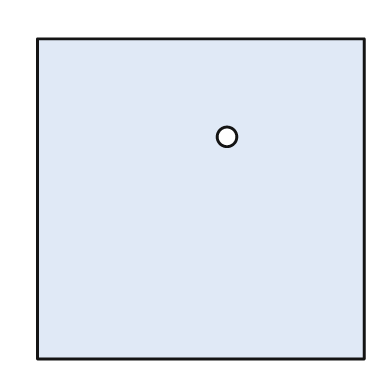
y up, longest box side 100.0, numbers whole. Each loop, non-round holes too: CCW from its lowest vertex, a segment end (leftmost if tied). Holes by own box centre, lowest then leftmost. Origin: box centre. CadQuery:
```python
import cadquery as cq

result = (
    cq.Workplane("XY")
    .moveTo(-50.0, -49.0)
    .lineTo(50.0, -49.0)
    .lineTo(50.0, 49.0)
    .lineTo(-50.0, 49.0)
    .close()
    .moveTo(8.0, 19.0)
    .circle(3.0)
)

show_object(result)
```